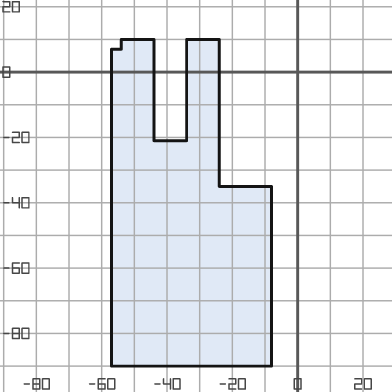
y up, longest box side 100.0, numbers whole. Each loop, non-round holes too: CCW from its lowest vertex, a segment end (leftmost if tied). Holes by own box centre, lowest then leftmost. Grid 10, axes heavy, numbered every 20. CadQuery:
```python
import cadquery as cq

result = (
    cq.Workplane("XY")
    .moveTo(-57.0, -90.0)
    .lineTo(-8.0, -90.0)
    .lineTo(-8.0, -35.0)
    .lineTo(-24.0, -35.0)
    .lineTo(-24.0, 10.0)
    .lineTo(-34.0, 10.0)
    .lineTo(-34.0, -21.0)
    .lineTo(-44.0, -21.0)
    .lineTo(-44.0, 10.0)
    .lineTo(-54.0, 10.0)
    .lineTo(-54.0, 7.0)
    .lineTo(-57.0, 7.0)
    .close()
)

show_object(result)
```